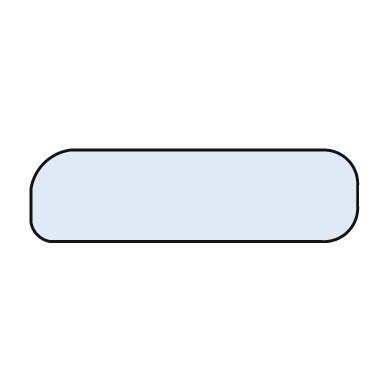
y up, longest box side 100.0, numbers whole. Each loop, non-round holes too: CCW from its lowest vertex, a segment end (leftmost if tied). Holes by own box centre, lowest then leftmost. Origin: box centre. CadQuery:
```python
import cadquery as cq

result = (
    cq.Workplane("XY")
    .moveTo(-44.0, -14.0)
    .lineTo(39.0, -14.0)
    .threePointArc((47.0, -11.0), (50.0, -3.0))
    .lineTo(50.0, 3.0)
    .threePointArc((47.0, 11.0), (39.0, 14.0))
    .lineTo(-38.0, 14.0)
    .threePointArc((-46.0, 10.0), (-50.0, 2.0))
    .lineTo(-50.0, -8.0)
    .threePointArc((-48.0, -12.0), (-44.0, -14.0))
    .close()
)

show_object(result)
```